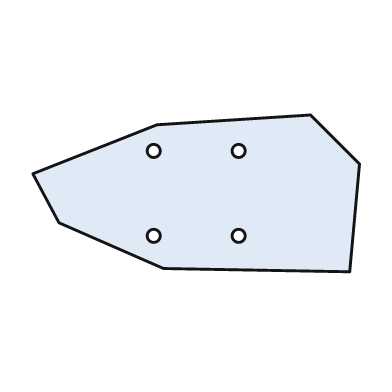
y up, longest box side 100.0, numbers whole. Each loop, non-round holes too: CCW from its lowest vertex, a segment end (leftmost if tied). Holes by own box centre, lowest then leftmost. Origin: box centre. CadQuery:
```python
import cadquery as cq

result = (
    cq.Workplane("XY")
    .moveTo(47.0, -24.0)
    .lineTo(50.0, 9.0)
    .lineTo(35.0, 24.0)
    .lineTo(-12.0, 21.0)
    .lineTo(-50.0, 6.0)
    .lineTo(-42.0, -9.0)
    .lineTo(-10.0, -23.0)
    .close()
    .moveTo(-13.0, -13.0)
    .circle(2.0)
    .moveTo(13.0, -13.0)
    .circle(2.0)
    .moveTo(-13.0, 13.0)
    .circle(2.0)
    .moveTo(13.0, 13.0)
    .circle(2.0)
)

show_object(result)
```